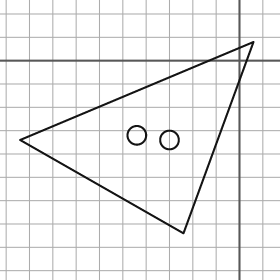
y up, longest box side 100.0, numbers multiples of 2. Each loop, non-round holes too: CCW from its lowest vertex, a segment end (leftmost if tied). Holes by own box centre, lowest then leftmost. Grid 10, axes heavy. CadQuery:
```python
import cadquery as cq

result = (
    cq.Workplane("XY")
    .moveTo(-24.0, -74.0)
    .lineTo(6.0, 8.0)
    .lineTo(-94.0, -34.0)
    .close()
    .moveTo(-30.0, -34.0)
    .circle(4.0)
    .moveTo(-44.0, -32.0)
    .circle(4.0)
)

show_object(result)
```